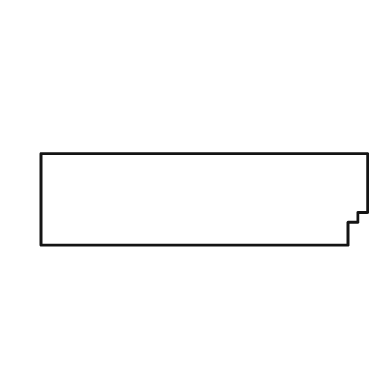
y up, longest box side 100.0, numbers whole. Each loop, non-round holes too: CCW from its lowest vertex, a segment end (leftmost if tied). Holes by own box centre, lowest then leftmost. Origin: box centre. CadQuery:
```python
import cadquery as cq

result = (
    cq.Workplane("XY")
    .moveTo(-50.0, -14.0)
    .lineTo(44.0, -14.0)
    .lineTo(44.0, -7.0)
    .lineTo(47.0, -7.0)
    .lineTo(47.0, -4.0)
    .lineTo(50.0, -4.0)
    .lineTo(50.0, 14.0)
    .lineTo(-50.0, 14.0)
    .close()
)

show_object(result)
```